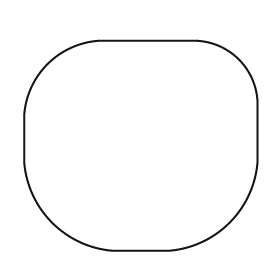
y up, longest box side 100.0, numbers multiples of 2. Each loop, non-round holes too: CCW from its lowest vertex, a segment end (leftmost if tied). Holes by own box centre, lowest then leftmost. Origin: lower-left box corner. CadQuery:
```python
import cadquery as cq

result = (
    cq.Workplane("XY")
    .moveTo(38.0, 0.0)
    .lineTo(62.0, 0.0)
    .threePointArc((88.0, 12.0), (100.0, 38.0))
    .lineTo(100.0, 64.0)
    .threePointArc((92.0, 82.0), (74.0, 90.0))
    .lineTo(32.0, 90.0)
    .threePointArc((10.0, 80.0), (0.0, 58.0))
    .lineTo(0.0, 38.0)
    .threePointArc((12.0, 12.0), (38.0, 0.0))
    .close()
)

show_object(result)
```